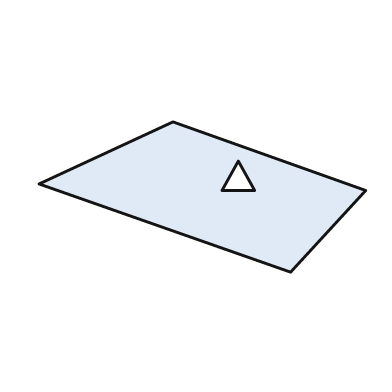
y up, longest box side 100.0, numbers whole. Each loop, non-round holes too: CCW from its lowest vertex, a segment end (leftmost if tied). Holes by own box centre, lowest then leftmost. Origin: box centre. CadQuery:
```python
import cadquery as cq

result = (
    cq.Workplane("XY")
    .moveTo(27.0, -23.0)
    .lineTo(50.0, 2.0)
    .lineTo(-9.0, 23.0)
    .lineTo(-50.0, 4.0)
    .close()
    .moveTo(6.0, 2.0)
    .lineTo(16.0, 2.0)
    .lineTo(11.0, 11.0)
    .close()
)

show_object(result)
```